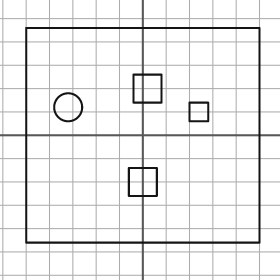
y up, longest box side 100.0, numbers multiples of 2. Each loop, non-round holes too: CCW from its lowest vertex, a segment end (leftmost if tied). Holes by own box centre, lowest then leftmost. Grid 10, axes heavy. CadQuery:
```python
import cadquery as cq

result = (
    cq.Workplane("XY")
    .moveTo(-50.0, -46.0)
    .lineTo(50.0, -46.0)
    .lineTo(50.0, 46.0)
    .lineTo(-50.0, 46.0)
    .close()
    .moveTo(-6.0, -26.0)
    .lineTo(6.0, -26.0)
    .lineTo(6.0, -14.0)
    .lineTo(-6.0, -14.0)
    .close()
    .moveTo(20.0, 6.0)
    .lineTo(28.0, 6.0)
    .lineTo(28.0, 14.0)
    .lineTo(20.0, 14.0)
    .close()
    .moveTo(-32.0, 12.0)
    .circle(6.0)
    .moveTo(-4.0, 14.0)
    .lineTo(8.0, 14.0)
    .lineTo(8.0, 26.0)
    .lineTo(-4.0, 26.0)
    .close()
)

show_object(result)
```